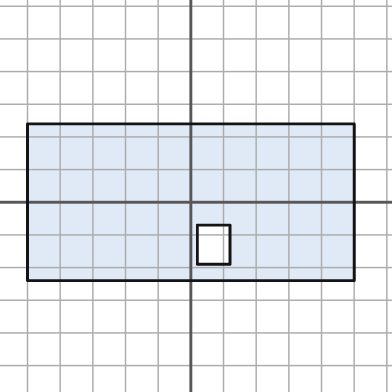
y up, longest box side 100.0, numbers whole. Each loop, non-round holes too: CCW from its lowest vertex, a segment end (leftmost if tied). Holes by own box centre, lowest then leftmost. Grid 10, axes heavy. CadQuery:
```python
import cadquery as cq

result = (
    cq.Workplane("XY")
    .moveTo(-50.0, -24.0)
    .lineTo(50.0, -24.0)
    .lineTo(50.0, 24.0)
    .lineTo(-50.0, 24.0)
    .close()
    .moveTo(2.0, -19.0)
    .lineTo(12.0, -19.0)
    .lineTo(12.0, -7.0)
    .lineTo(2.0, -7.0)
    .close()
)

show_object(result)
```